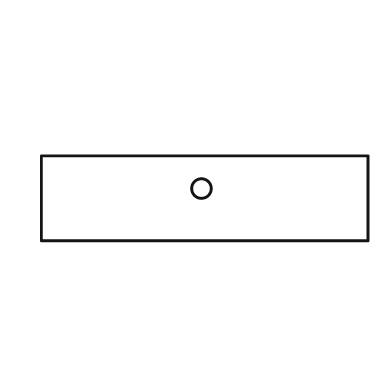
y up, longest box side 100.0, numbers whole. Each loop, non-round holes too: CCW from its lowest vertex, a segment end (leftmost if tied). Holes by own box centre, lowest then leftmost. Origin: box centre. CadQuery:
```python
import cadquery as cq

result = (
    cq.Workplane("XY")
    .moveTo(-50.0, -13.0)
    .lineTo(50.0, -13.0)
    .lineTo(50.0, 13.0)
    .lineTo(-50.0, 13.0)
    .close()
    .moveTo(-1.0, 3.0)
    .circle(3.0)
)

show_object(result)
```